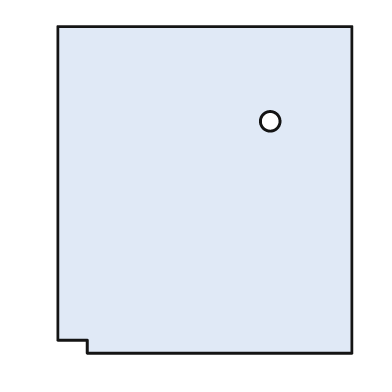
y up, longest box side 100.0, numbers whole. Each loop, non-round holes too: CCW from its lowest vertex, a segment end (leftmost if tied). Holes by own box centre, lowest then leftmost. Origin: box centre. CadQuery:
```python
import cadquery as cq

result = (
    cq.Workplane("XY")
    .moveTo(-36.0, -50.0)
    .lineTo(45.0, -50.0)
    .lineTo(45.0, 50.0)
    .lineTo(-45.0, 50.0)
    .lineTo(-45.0, -46.0)
    .lineTo(-36.0, -46.0)
    .close()
    .moveTo(20.0, 21.0)
    .circle(3.0)
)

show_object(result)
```